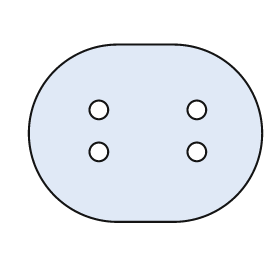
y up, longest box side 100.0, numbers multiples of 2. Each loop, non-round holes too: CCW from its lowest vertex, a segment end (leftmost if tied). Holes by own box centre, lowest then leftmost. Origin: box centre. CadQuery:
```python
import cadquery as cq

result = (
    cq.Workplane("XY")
    .moveTo(-12.0, -38.0)
    .lineTo(12.0, -38.0)
    .threePointArc((50.0, 0.0), (12.0, 38.0))
    .lineTo(-12.0, 38.0)
    .threePointArc((-50.0, 0.0), (-12.0, -38.0))
    .close()
    .moveTo(-20.0, -8.0)
    .circle(4.0)
    .moveTo(22.0, -8.0)
    .circle(4.0)
    .moveTo(-20.0, 10.0)
    .circle(4.0)
    .moveTo(22.0, 10.0)
    .circle(4.0)
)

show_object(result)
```